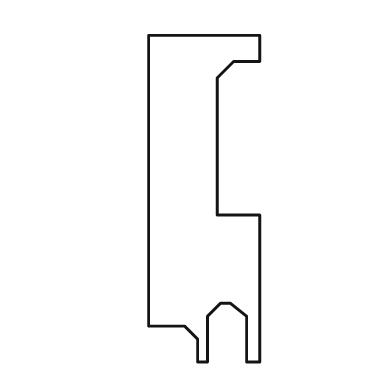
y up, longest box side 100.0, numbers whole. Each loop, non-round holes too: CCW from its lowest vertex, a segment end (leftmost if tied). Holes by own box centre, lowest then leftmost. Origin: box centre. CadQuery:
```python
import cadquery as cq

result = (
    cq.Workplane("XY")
    .moveTo(-2.0, -50.0)
    .lineTo(1.0, -50.0)
    .lineTo(1.0, -36.0)
    .lineTo(5.0, -32.0)
    .lineTo(8.0, -32.0)
    .lineTo(13.0, -36.0)
    .lineTo(13.0, -50.0)
    .lineTo(17.0, -50.0)
    .lineTo(17.0, -5.0)
    .lineTo(4.0, -5.0)
    .lineTo(4.0, 37.0)
    .lineTo(9.0, 42.0)
    .lineTo(17.0, 42.0)
    .lineTo(17.0, 50.0)
    .lineTo(-17.0, 50.0)
    .lineTo(-17.0, -39.0)
    .lineTo(-6.0, -39.0)
    .lineTo(-2.0, -43.0)
    .close()
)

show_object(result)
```